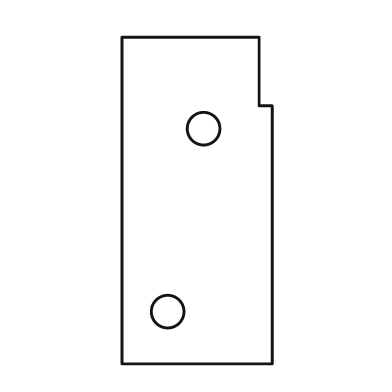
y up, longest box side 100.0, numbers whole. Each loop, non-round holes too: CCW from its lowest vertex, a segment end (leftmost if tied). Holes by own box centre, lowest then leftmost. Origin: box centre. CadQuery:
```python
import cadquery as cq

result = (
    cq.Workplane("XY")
    .moveTo(-23.0, -50.0)
    .lineTo(23.0, -50.0)
    .lineTo(23.0, 29.0)
    .lineTo(19.0, 29.0)
    .lineTo(19.0, 50.0)
    .lineTo(-23.0, 50.0)
    .close()
    .moveTo(-9.0, -34.0)
    .circle(5.0)
    .moveTo(2.0, 22.0)
    .circle(5.0)
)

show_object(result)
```